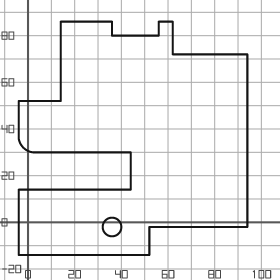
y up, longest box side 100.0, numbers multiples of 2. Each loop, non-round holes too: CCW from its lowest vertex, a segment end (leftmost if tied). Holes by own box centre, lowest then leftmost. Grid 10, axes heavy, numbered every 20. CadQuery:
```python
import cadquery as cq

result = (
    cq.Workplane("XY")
    .moveTo(-4.0, -14.0)
    .lineTo(52.0, -14.0)
    .lineTo(52.0, -2.0)
    .lineTo(94.0, -2.0)
    .lineTo(94.0, 72.0)
    .lineTo(62.0, 72.0)
    .lineTo(62.0, 86.0)
    .lineTo(56.0, 86.0)
    .lineTo(56.0, 80.0)
    .lineTo(36.0, 80.0)
    .lineTo(36.0, 86.0)
    .lineTo(14.0, 86.0)
    .lineTo(14.0, 52.0)
    .lineTo(-4.0, 52.0)
    .lineTo(-4.0, 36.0)
    .threePointArc((-2.0, 32.0), (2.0, 30.0))
    .lineTo(44.0, 30.0)
    .lineTo(44.0, 14.0)
    .lineTo(-4.0, 14.0)
    .close()
    .moveTo(36.0, -2.0)
    .circle(4.0)
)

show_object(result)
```